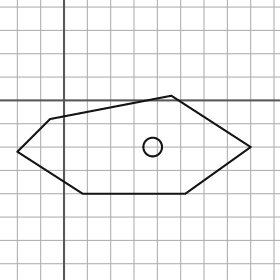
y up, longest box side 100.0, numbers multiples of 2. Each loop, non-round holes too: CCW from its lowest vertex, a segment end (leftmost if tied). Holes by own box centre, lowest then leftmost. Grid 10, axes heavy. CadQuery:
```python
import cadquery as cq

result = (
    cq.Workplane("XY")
    .moveTo(8.0, -40.0)
    .lineTo(52.0, -40.0)
    .lineTo(80.0, -20.0)
    .lineTo(46.0, 2.0)
    .lineTo(-6.0, -8.0)
    .lineTo(-20.0, -22.0)
    .close()
    .moveTo(38.0, -20.0)
    .circle(4.0)
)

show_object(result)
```